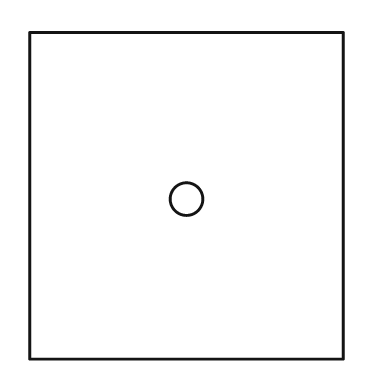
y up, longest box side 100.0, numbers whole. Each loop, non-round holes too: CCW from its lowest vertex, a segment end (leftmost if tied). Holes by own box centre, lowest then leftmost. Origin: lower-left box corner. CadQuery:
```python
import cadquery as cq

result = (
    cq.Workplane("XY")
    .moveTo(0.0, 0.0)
    .lineTo(96.0, 0.0)
    .lineTo(96.0, 100.0)
    .lineTo(0.0, 100.0)
    .close()
    .moveTo(48.0, 49.0)
    .circle(5.0)
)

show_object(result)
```